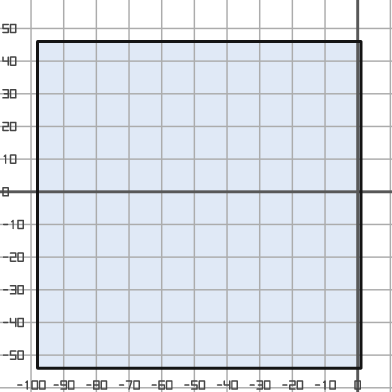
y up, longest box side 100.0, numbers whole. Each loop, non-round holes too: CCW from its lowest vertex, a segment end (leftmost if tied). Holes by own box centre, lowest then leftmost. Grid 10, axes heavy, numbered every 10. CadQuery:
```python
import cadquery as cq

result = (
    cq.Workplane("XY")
    .moveTo(-98.0, -54.0)
    .lineTo(1.0, -54.0)
    .lineTo(1.0, 46.0)
    .lineTo(-98.0, 46.0)
    .close()
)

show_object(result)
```